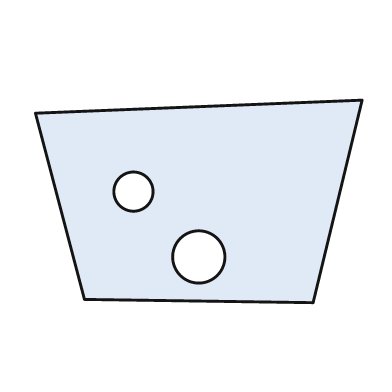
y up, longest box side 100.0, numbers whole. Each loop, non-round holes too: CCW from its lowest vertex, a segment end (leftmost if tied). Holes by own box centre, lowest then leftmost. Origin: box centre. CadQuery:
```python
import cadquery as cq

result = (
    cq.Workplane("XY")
    .moveTo(35.0, -31.0)
    .lineTo(50.0, 31.0)
    .lineTo(-50.0, 27.0)
    .lineTo(-35.0, -30.0)
    .close()
    .moveTo(0.0, -17.0)
    .circle(8.0)
    .moveTo(-20.0, 3.0)
    .circle(6.0)
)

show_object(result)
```